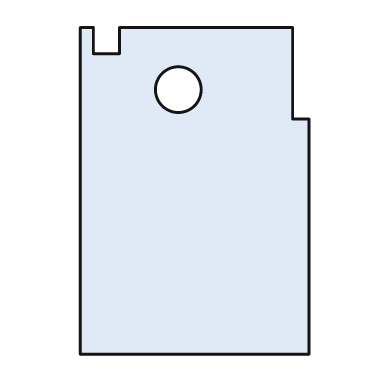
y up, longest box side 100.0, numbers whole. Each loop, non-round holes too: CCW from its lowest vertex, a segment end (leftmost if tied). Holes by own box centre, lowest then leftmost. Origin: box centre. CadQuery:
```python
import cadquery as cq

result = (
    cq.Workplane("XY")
    .moveTo(-35.0, -50.0)
    .lineTo(35.0, -50.0)
    .lineTo(35.0, 22.0)
    .lineTo(30.0, 22.0)
    .lineTo(30.0, 50.0)
    .lineTo(-23.0, 50.0)
    .lineTo(-23.0, 42.0)
    .lineTo(-31.0, 42.0)
    .lineTo(-31.0, 50.0)
    .lineTo(-35.0, 50.0)
    .close()
    .moveTo(-5.0, 31.0)
    .circle(7.0)
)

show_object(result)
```